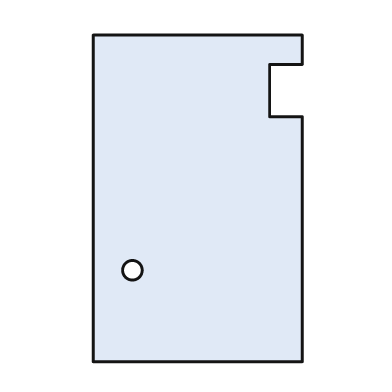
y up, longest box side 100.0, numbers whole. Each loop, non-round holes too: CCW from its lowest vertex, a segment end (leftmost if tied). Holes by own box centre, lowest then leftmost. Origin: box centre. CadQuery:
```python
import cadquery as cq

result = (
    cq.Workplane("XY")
    .moveTo(-32.0, -50.0)
    .lineTo(32.0, -50.0)
    .lineTo(32.0, 25.0)
    .lineTo(22.0, 25.0)
    .lineTo(22.0, 41.0)
    .lineTo(32.0, 41.0)
    .lineTo(32.0, 50.0)
    .lineTo(-32.0, 50.0)
    .close()
    .moveTo(-20.0, -22.0)
    .circle(3.0)
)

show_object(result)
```